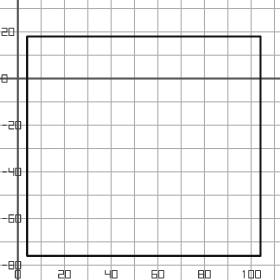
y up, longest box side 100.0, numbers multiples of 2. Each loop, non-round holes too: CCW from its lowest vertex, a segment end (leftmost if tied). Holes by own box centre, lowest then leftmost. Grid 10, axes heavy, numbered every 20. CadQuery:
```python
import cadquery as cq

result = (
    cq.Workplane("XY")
    .moveTo(4.0, -76.0)
    .lineTo(104.0, -76.0)
    .lineTo(104.0, 18.0)
    .lineTo(4.0, 18.0)
    .close()
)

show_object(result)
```